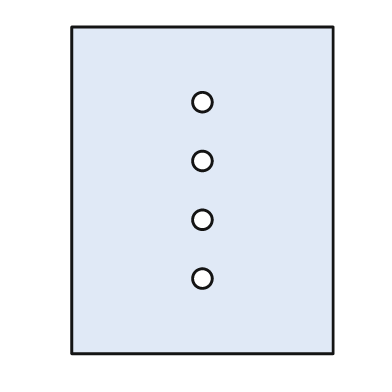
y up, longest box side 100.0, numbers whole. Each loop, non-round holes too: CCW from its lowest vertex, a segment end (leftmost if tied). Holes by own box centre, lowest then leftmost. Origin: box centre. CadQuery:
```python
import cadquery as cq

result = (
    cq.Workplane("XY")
    .moveTo(-40.0, -50.0)
    .lineTo(40.0, -50.0)
    .lineTo(40.0, 50.0)
    .lineTo(-40.0, 50.0)
    .close()
    .moveTo(0.0, -27.0)
    .circle(3.0)
    .moveTo(0.0, -9.0)
    .circle(3.0)
    .moveTo(0.0, 9.0)
    .circle(3.0)
    .moveTo(0.0, 27.0)
    .circle(3.0)
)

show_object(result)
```